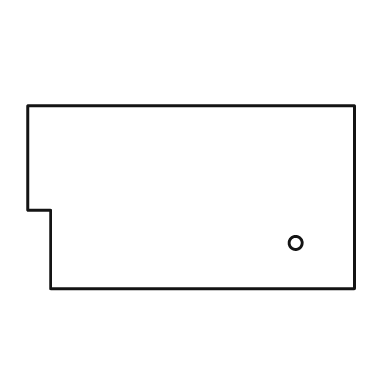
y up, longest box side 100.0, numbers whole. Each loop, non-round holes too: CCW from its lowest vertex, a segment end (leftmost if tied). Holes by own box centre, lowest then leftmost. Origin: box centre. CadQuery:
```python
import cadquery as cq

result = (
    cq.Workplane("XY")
    .moveTo(-43.0, -28.0)
    .lineTo(50.0, -28.0)
    .lineTo(50.0, 28.0)
    .lineTo(-50.0, 28.0)
    .lineTo(-50.0, -4.0)
    .lineTo(-43.0, -4.0)
    .close()
    .moveTo(32.0, -14.0)
    .circle(2.0)
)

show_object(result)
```